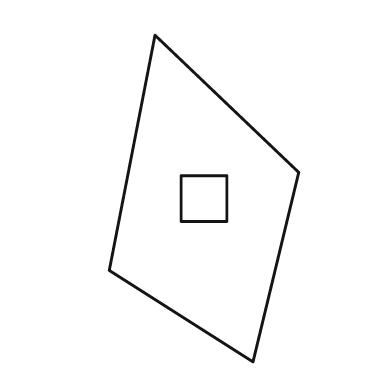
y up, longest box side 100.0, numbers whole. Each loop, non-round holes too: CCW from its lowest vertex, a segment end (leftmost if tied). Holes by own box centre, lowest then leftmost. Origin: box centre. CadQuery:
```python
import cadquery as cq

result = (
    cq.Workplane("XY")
    .moveTo(15.0, -50.0)
    .lineTo(29.0, 8.0)
    .lineTo(-15.0, 50.0)
    .lineTo(-29.0, -22.0)
    .close()
    .moveTo(-7.0, -7.0)
    .lineTo(7.0, -7.0)
    .lineTo(7.0, 7.0)
    .lineTo(-7.0, 7.0)
    .close()
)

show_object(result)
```